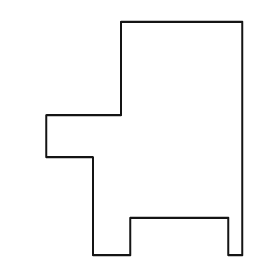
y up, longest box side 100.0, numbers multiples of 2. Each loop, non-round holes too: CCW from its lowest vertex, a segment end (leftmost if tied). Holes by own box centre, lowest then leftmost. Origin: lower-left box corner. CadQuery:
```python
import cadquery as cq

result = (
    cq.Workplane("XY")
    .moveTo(20.0, 0.0)
    .lineTo(36.0, 0.0)
    .lineTo(36.0, 16.0)
    .lineTo(78.0, 16.0)
    .lineTo(78.0, 0.0)
    .lineTo(84.0, 0.0)
    .lineTo(84.0, 100.0)
    .lineTo(32.0, 100.0)
    .lineTo(32.0, 60.0)
    .lineTo(0.0, 60.0)
    .lineTo(0.0, 42.0)
    .lineTo(20.0, 42.0)
    .close()
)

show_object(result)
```